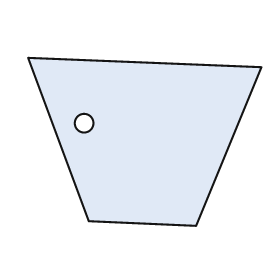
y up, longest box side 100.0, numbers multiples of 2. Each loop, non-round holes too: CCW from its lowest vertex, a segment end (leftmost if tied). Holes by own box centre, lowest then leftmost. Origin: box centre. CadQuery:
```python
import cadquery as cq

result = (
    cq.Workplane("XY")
    .moveTo(22.0, -36.0)
    .lineTo(50.0, 32.0)
    .lineTo(-50.0, 36.0)
    .lineTo(-24.0, -34.0)
    .close()
    .moveTo(-26.0, 8.0)
    .circle(4.0)
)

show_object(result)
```